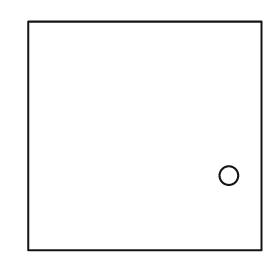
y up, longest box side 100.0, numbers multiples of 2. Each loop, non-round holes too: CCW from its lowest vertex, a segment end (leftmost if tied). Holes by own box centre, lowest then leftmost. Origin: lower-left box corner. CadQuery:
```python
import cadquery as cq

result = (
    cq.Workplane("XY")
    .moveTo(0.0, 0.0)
    .lineTo(100.0, 0.0)
    .lineTo(100.0, 98.0)
    .lineTo(0.0, 98.0)
    .close()
    .moveTo(86.0, 32.0)
    .circle(4.0)
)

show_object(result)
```